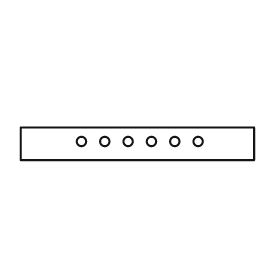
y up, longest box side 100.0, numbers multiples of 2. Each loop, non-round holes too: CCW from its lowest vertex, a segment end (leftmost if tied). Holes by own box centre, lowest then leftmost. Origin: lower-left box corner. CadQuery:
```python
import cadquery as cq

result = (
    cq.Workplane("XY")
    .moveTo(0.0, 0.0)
    .lineTo(100.0, 0.0)
    .lineTo(100.0, 14.0)
    .lineTo(0.0, 14.0)
    .close()
    .moveTo(26.0, 8.0)
    .circle(2.0)
    .moveTo(36.0, 8.0)
    .circle(2.0)
    .moveTo(46.0, 8.0)
    .circle(2.0)
    .moveTo(56.0, 8.0)
    .circle(2.0)
    .moveTo(66.0, 8.0)
    .circle(2.0)
    .moveTo(76.0, 8.0)
    .circle(2.0)
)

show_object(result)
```